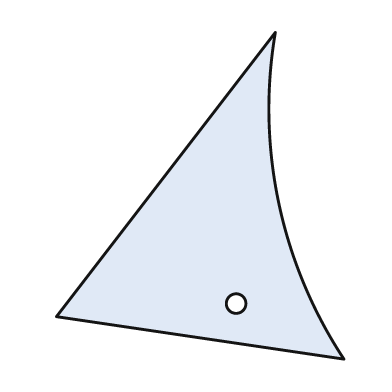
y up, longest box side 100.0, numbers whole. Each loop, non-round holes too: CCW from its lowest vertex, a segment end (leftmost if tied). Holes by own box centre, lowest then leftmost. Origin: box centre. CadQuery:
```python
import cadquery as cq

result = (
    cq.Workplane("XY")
    .moveTo(44.0, -50.0)
    .threePointArc((24.0, -2.0), (23.0, 50.0))
    .lineTo(-44.0, -37.0)
    .close()
    .moveTo(11.0, -33.0)
    .circle(3.0)
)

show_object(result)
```